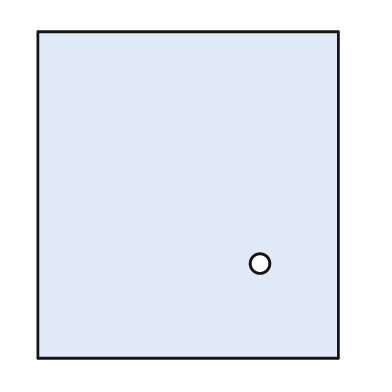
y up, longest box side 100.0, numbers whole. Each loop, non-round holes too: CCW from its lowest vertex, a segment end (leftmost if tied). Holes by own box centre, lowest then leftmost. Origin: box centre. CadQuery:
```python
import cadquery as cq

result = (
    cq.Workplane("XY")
    .moveTo(-46.0, -50.0)
    .lineTo(46.0, -50.0)
    .lineTo(46.0, 50.0)
    .lineTo(-46.0, 50.0)
    .close()
    .moveTo(22.0, -21.0)
    .circle(3.0)
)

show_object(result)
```